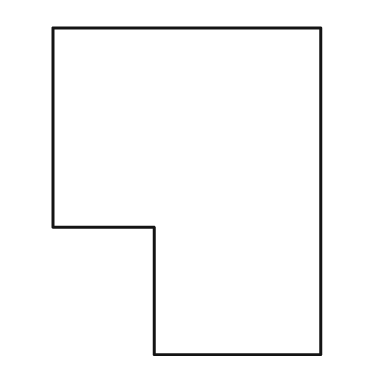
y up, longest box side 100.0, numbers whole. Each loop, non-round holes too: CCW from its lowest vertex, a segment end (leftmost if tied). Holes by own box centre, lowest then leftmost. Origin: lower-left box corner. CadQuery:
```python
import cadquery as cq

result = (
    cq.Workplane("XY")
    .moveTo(31.0, 0.0)
    .lineTo(82.0, 0.0)
    .lineTo(82.0, 100.0)
    .lineTo(0.0, 100.0)
    .lineTo(0.0, 39.0)
    .lineTo(31.0, 39.0)
    .close()
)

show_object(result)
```